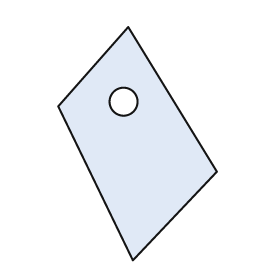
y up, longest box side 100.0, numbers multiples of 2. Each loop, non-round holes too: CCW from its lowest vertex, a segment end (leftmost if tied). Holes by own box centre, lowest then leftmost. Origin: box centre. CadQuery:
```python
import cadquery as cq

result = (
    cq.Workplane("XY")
    .moveTo(-2.0, -50.0)
    .lineTo(34.0, -12.0)
    .lineTo(-4.0, 50.0)
    .lineTo(-34.0, 16.0)
    .close()
    .moveTo(-6.0, 18.0)
    .circle(6.0)
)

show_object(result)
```